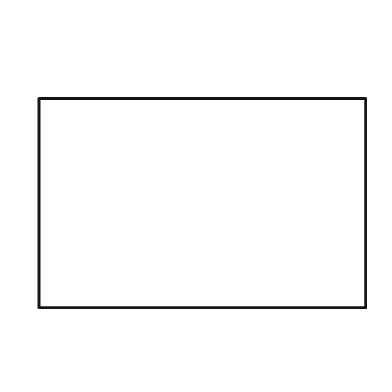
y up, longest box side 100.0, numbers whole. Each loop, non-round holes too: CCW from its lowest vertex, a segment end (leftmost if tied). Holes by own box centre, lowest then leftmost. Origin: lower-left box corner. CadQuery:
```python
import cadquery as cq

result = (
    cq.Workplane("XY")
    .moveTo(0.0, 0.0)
    .lineTo(100.0, 0.0)
    .lineTo(100.0, 64.0)
    .lineTo(0.0, 64.0)
    .close()
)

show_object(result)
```